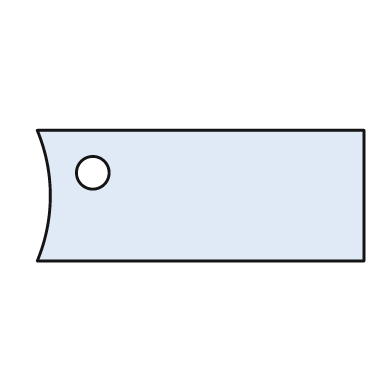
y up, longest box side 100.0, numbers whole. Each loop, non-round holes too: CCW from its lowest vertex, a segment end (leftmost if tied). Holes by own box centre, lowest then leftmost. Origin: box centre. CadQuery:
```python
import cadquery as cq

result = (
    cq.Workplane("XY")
    .moveTo(-50.0, -20.0)
    .lineTo(50.0, -20.0)
    .lineTo(50.0, 20.0)
    .lineTo(-50.0, 20.0)
    .threePointArc((-46.0, 0.0), (-50.0, -20.0))
    .close()
    .moveTo(-33.0, 7.0)
    .circle(5.0)
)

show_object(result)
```